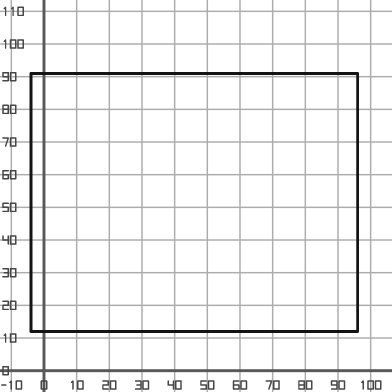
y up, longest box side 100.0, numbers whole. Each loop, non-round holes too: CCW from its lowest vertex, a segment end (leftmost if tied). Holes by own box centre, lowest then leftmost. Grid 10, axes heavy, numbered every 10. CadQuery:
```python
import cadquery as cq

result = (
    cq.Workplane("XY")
    .moveTo(-4.0, 12.0)
    .lineTo(96.0, 12.0)
    .lineTo(96.0, 91.0)
    .lineTo(-4.0, 91.0)
    .close()
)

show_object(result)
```